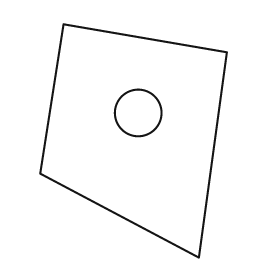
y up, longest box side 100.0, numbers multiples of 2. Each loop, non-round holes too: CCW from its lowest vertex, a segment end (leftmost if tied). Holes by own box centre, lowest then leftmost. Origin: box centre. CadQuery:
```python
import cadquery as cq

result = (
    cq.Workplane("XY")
    .moveTo(28.0, -50.0)
    .lineTo(40.0, 38.0)
    .lineTo(-30.0, 50.0)
    .lineTo(-40.0, -14.0)
    .close()
    .moveTo(2.0, 12.0)
    .circle(10.0)
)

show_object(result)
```